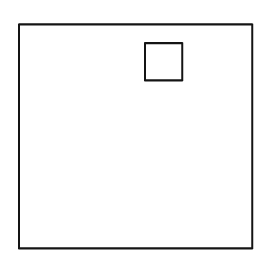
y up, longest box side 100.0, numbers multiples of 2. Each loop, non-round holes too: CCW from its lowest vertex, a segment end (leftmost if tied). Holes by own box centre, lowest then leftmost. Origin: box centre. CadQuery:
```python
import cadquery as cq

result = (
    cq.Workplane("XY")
    .moveTo(-50.0, -48.0)
    .lineTo(50.0, -48.0)
    .lineTo(50.0, 48.0)
    .lineTo(-50.0, 48.0)
    .close()
    .moveTo(4.0, 24.0)
    .lineTo(20.0, 24.0)
    .lineTo(20.0, 40.0)
    .lineTo(4.0, 40.0)
    .close()
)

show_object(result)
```